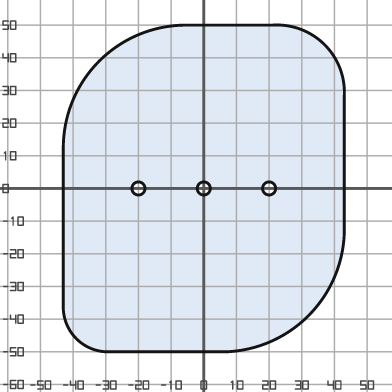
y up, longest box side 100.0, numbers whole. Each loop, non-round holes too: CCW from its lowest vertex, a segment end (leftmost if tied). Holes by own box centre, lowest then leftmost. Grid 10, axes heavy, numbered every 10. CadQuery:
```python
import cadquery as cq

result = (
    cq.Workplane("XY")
    .moveTo(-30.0, -50.0)
    .lineTo(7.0, -50.0)
    .threePointArc((32.0, -39.0), (43.0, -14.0))
    .lineTo(43.0, 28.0)
    .threePointArc((37.0, 44.0), (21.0, 50.0))
    .lineTo(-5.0, 50.0)
    .threePointArc((-32.0, 39.0), (-43.0, 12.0))
    .lineTo(-43.0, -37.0)
    .threePointArc((-39.0, -46.0), (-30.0, -50.0))
    .close()
    .moveTo(-20.0, 0.0)
    .circle(2.0)
    .moveTo(0.0, 0.0)
    .circle(2.0)
    .moveTo(20.0, 0.0)
    .circle(2.0)
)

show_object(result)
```